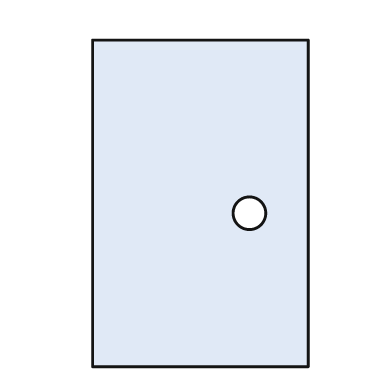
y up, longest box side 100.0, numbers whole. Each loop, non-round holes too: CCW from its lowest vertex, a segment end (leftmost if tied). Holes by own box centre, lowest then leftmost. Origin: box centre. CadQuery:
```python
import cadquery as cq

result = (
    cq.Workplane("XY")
    .moveTo(-33.0, -50.0)
    .lineTo(33.0, -50.0)
    .lineTo(33.0, 50.0)
    .lineTo(-33.0, 50.0)
    .close()
    .moveTo(15.0, -3.0)
    .circle(5.0)
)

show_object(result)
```